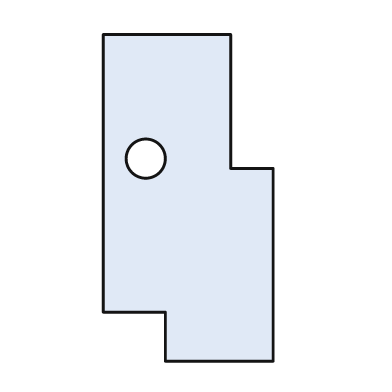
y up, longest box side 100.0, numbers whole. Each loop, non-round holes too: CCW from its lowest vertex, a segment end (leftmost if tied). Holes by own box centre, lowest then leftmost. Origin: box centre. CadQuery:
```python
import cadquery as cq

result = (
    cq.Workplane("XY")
    .moveTo(-7.0, -50.0)
    .lineTo(26.0, -50.0)
    .lineTo(26.0, 9.0)
    .lineTo(13.0, 9.0)
    .lineTo(13.0, 50.0)
    .lineTo(-26.0, 50.0)
    .lineTo(-26.0, -35.0)
    .lineTo(-7.0, -35.0)
    .close()
    .moveTo(-13.0, 12.0)
    .circle(6.0)
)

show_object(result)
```